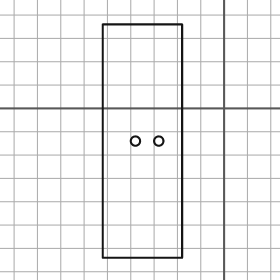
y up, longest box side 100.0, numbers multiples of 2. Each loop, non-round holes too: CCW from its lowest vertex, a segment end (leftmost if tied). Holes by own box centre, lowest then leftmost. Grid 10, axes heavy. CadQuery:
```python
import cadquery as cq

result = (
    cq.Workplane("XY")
    .moveTo(-52.0, -64.0)
    .lineTo(-18.0, -64.0)
    .lineTo(-18.0, 36.0)
    .lineTo(-52.0, 36.0)
    .close()
    .moveTo(-38.0, -14.0)
    .circle(2.0)
    .moveTo(-28.0, -14.0)
    .circle(2.0)
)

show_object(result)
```